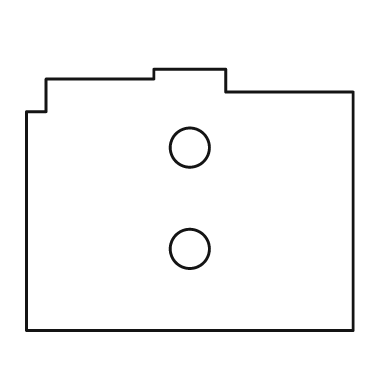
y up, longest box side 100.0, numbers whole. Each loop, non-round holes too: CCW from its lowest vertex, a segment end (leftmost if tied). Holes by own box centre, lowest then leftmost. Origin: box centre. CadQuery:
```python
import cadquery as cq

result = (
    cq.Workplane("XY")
    .moveTo(-50.0, -40.0)
    .lineTo(50.0, -40.0)
    .lineTo(50.0, 33.0)
    .lineTo(11.0, 33.0)
    .lineTo(11.0, 40.0)
    .lineTo(-11.0, 40.0)
    .lineTo(-11.0, 37.0)
    .lineTo(-44.0, 37.0)
    .lineTo(-44.0, 27.0)
    .lineTo(-50.0, 27.0)
    .close()
    .moveTo(0.0, -15.0)
    .circle(6.0)
    .moveTo(0.0, 16.0)
    .circle(6.0)
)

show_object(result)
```